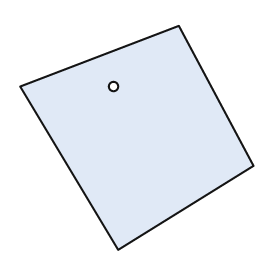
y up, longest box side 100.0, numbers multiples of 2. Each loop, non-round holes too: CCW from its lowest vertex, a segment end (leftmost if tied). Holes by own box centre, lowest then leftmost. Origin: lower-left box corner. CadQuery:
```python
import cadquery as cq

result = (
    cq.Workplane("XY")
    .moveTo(42.0, 0.0)
    .lineTo(100.0, 36.0)
    .lineTo(68.0, 96.0)
    .lineTo(0.0, 70.0)
    .close()
    .moveTo(40.0, 70.0)
    .circle(2.0)
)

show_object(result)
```